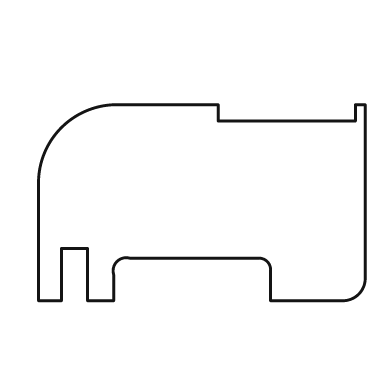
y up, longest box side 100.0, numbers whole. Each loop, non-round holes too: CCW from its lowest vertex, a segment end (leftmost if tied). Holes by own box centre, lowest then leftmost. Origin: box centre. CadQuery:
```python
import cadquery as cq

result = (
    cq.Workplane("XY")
    .moveTo(-50.0, -30.0)
    .lineTo(-43.0, -30.0)
    .lineTo(-43.0, -14.0)
    .lineTo(-35.0, -14.0)
    .lineTo(-35.0, -30.0)
    .lineTo(-27.0, -30.0)
    .lineTo(-27.0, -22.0)
    .threePointArc((-26.0, -18.0), (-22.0, -17.0))
    .lineTo(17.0, -17.0)
    .threePointArc((20.0, -18.0), (21.0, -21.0))
    .lineTo(21.0, -30.0)
    .lineTo(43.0, -30.0)
    .threePointArc((48.0, -28.0), (50.0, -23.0))
    .lineTo(50.0, 30.0)
    .lineTo(47.0, 30.0)
    .lineTo(47.0, 25.0)
    .lineTo(5.0, 25.0)
    .lineTo(5.0, 30.0)
    .lineTo(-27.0, 30.0)
    .threePointArc((-43.0, 23.0), (-50.0, 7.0))
    .close()
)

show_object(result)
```